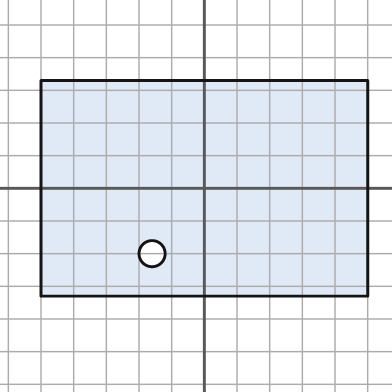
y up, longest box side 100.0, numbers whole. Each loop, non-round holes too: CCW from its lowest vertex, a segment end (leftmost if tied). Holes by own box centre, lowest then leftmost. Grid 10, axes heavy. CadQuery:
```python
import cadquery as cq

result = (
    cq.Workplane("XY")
    .moveTo(-50.0, -33.0)
    .lineTo(50.0, -33.0)
    .lineTo(50.0, 33.0)
    .lineTo(-50.0, 33.0)
    .close()
    .moveTo(-16.0, -20.0)
    .circle(4.0)
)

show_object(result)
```